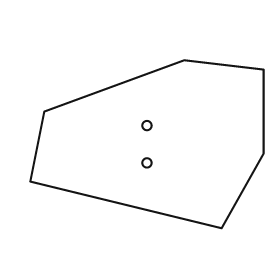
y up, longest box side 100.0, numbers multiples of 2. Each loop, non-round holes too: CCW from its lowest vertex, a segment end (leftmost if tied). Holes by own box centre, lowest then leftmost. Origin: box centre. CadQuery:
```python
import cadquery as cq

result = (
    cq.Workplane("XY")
    .moveTo(32.0, -36.0)
    .lineTo(50.0, -4.0)
    .lineTo(50.0, 32.0)
    .lineTo(16.0, 36.0)
    .lineTo(-44.0, 14.0)
    .lineTo(-50.0, -16.0)
    .close()
    .moveTo(0.0, -8.0)
    .circle(2.0)
    .moveTo(0.0, 8.0)
    .circle(2.0)
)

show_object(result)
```